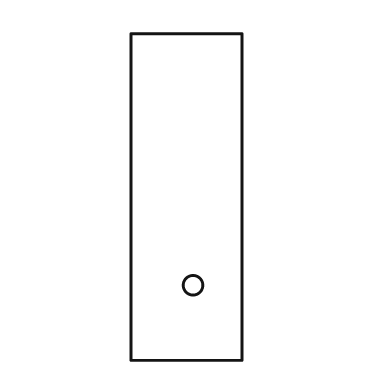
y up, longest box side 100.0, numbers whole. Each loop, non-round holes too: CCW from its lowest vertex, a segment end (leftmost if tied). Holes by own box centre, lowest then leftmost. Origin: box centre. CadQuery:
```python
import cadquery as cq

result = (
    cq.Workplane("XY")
    .moveTo(-17.0, -50.0)
    .lineTo(17.0, -50.0)
    .lineTo(17.0, 50.0)
    .lineTo(-17.0, 50.0)
    .close()
    .moveTo(2.0, -27.0)
    .circle(3.0)
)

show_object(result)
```